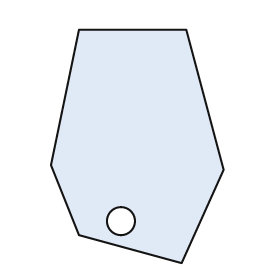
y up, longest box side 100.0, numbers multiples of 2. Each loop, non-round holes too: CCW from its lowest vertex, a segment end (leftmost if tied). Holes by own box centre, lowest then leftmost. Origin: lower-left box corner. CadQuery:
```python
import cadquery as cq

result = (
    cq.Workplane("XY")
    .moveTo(56.0, 0.0)
    .lineTo(74.0, 40.0)
    .lineTo(58.0, 100.0)
    .lineTo(12.0, 100.0)
    .lineTo(0.0, 42.0)
    .lineTo(12.0, 12.0)
    .close()
    .moveTo(30.0, 18.0)
    .circle(6.0)
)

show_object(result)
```